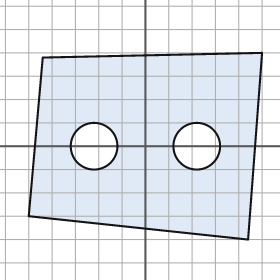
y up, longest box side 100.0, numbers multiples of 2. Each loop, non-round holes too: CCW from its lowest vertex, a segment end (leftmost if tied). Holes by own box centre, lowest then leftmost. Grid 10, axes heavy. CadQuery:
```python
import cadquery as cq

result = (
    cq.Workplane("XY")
    .moveTo(44.0, -40.0)
    .lineTo(50.0, 40.0)
    .lineTo(-44.0, 38.0)
    .lineTo(-50.0, -30.0)
    .close()
    .moveTo(-22.0, 0.0)
    .circle(10.0)
    .moveTo(22.0, 0.0)
    .circle(10.0)
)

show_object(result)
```